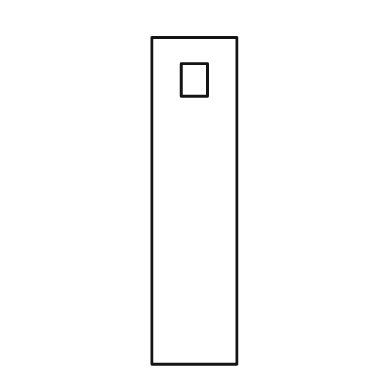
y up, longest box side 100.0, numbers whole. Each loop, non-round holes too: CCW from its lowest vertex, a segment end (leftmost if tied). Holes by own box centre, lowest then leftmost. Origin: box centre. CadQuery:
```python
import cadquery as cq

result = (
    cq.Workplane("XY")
    .moveTo(-13.0, -50.0)
    .lineTo(13.0, -50.0)
    .lineTo(13.0, 50.0)
    .lineTo(-13.0, 50.0)
    .close()
    .moveTo(-4.0, 32.0)
    .lineTo(4.0, 32.0)
    .lineTo(4.0, 42.0)
    .lineTo(-4.0, 42.0)
    .close()
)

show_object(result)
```